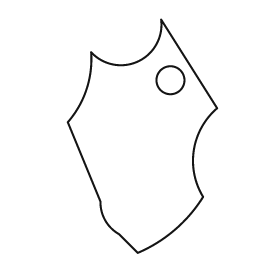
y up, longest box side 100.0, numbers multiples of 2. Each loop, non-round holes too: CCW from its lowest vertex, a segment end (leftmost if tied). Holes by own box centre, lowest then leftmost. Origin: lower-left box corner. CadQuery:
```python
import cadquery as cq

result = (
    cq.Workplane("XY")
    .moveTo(30.0, 0.0)
    .threePointArc((46.0, 10.0), (58.0, 24.0))
    .threePointArc((54.0, 44.0), (64.0, 62.0))
    .lineTo(40.0, 100.0)
    .threePointArc((30.0, 82.0), (10.0, 86.0))
    .threePointArc((8.0, 70.0), (0.0, 56.0))
    .lineTo(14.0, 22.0)
    .threePointArc((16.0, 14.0), (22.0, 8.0))
    .close()
    .moveTo(44.0, 74.0)
    .circle(6.0)
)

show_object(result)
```